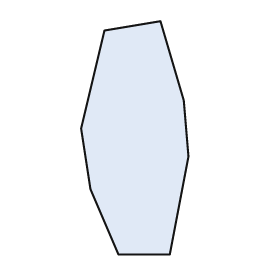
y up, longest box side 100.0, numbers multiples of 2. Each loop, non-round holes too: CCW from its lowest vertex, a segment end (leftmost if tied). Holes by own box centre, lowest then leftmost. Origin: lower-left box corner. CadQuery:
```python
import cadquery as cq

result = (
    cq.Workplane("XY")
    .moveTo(16.0, 0.0)
    .lineTo(38.0, 0.0)
    .lineTo(46.0, 42.0)
    .lineTo(44.0, 66.0)
    .lineTo(34.0, 100.0)
    .lineTo(10.0, 96.0)
    .lineTo(0.0, 54.0)
    .lineTo(4.0, 28.0)
    .close()
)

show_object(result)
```